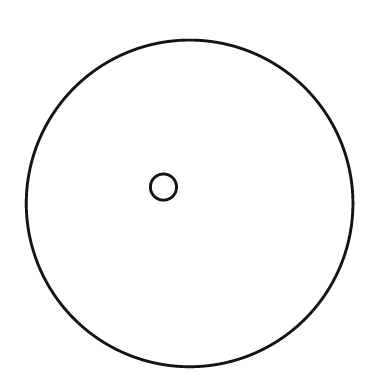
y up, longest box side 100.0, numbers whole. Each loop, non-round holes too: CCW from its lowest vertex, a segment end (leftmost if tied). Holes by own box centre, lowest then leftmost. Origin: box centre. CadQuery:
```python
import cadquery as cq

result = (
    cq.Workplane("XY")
    .moveTo(0.0, 0.0)
    .circle(50.0)
    .moveTo(-8.0, 5.0)
    .circle(4.0)
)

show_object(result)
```